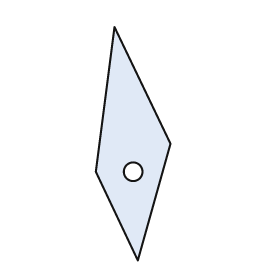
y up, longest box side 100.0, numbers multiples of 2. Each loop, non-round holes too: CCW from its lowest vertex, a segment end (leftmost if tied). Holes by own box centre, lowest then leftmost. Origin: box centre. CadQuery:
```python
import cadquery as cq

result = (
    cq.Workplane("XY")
    .moveTo(2.0, -50.0)
    .lineTo(16.0, 0.0)
    .lineTo(-8.0, 50.0)
    .lineTo(-16.0, -12.0)
    .close()
    .moveTo(0.0, -12.0)
    .circle(4.0)
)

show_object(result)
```